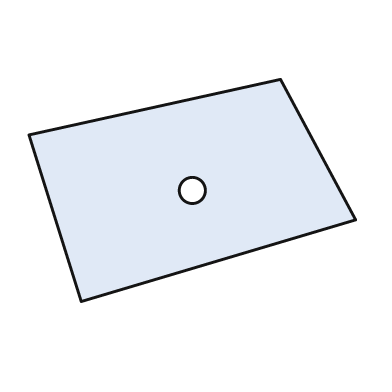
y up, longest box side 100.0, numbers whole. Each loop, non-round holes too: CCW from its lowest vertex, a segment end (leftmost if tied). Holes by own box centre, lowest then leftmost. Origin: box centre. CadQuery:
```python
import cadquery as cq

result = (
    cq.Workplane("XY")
    .moveTo(-34.0, -34.0)
    .lineTo(50.0, -9.0)
    .lineTo(27.0, 34.0)
    .lineTo(-50.0, 17.0)
    .close()
    .moveTo(0.0, 0.0)
    .circle(4.0)
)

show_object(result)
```